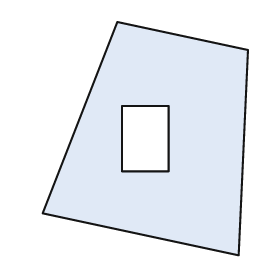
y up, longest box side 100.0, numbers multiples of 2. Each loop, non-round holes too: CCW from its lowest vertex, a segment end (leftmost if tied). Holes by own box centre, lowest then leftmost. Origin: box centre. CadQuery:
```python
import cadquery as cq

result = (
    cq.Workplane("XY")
    .moveTo(40.0, -50.0)
    .lineTo(44.0, 38.0)
    .lineTo(-12.0, 50.0)
    .lineTo(-44.0, -32.0)
    .close()
    .moveTo(-10.0, -14.0)
    .lineTo(10.0, -14.0)
    .lineTo(10.0, 14.0)
    .lineTo(-10.0, 14.0)
    .close()
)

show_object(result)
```